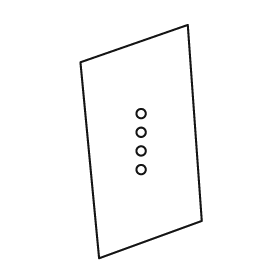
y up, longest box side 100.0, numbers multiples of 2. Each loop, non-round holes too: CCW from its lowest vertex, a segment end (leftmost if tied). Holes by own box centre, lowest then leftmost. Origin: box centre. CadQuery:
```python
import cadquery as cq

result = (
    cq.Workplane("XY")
    .moveTo(-18.0, -50.0)
    .lineTo(26.0, -34.0)
    .lineTo(20.0, 50.0)
    .lineTo(-26.0, 34.0)
    .close()
    .moveTo(0.0, -12.0)
    .circle(2.0)
    .moveTo(0.0, -4.0)
    .circle(2.0)
    .moveTo(0.0, 4.0)
    .circle(2.0)
    .moveTo(0.0, 12.0)
    .circle(2.0)
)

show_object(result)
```